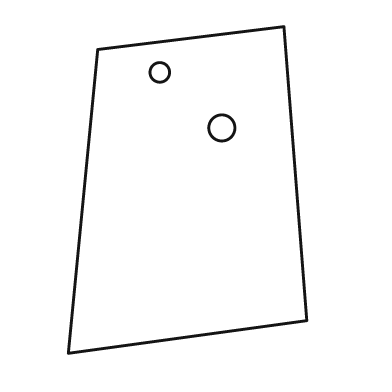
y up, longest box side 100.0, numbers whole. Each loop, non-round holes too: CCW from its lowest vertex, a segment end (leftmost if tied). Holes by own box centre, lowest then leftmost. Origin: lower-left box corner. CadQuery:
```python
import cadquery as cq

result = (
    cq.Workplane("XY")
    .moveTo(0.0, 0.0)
    .lineTo(73.0, 10.0)
    .lineTo(66.0, 100.0)
    .lineTo(9.0, 93.0)
    .close()
    .moveTo(47.0, 69.0)
    .circle(4.0)
    .moveTo(28.0, 86.0)
    .circle(3.0)
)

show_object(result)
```